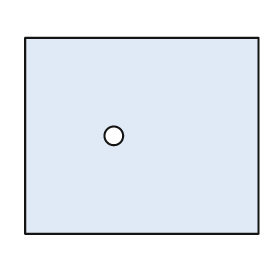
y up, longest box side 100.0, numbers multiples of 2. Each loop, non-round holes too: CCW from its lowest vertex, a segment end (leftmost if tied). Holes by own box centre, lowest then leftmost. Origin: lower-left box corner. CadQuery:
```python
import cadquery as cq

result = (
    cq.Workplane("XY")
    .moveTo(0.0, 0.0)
    .lineTo(100.0, 0.0)
    .lineTo(100.0, 84.0)
    .lineTo(0.0, 84.0)
    .close()
    .moveTo(38.0, 42.0)
    .circle(4.0)
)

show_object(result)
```